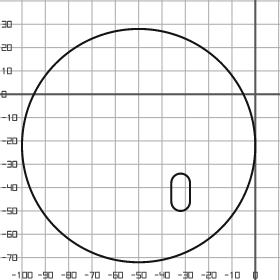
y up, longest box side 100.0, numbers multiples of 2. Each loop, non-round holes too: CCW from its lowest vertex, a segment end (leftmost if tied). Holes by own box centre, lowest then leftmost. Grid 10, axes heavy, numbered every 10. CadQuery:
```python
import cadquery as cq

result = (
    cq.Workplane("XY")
    .moveTo(-50.0, -22.0)
    .circle(50.0)
    .moveTo(-36.0, -46.0)
    .threePointArc((-32.0, -50.0), (-28.0, -46.0))
    .lineTo(-28.0, -38.0)
    .threePointArc((-32.0, -34.0), (-36.0, -38.0))
    .close()
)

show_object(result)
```